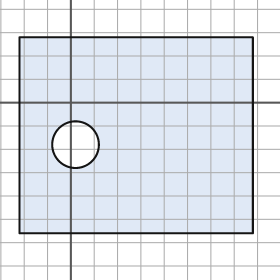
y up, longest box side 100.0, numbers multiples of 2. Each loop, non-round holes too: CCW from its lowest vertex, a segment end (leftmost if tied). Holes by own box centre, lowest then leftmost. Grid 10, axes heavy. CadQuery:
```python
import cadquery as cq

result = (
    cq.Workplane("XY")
    .moveTo(-22.0, -56.0)
    .lineTo(78.0, -56.0)
    .lineTo(78.0, 28.0)
    .lineTo(-22.0, 28.0)
    .close()
    .moveTo(2.0, -18.0)
    .circle(10.0)
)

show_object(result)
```